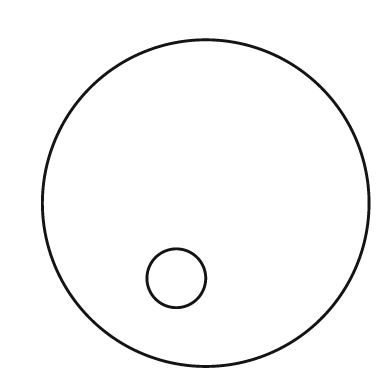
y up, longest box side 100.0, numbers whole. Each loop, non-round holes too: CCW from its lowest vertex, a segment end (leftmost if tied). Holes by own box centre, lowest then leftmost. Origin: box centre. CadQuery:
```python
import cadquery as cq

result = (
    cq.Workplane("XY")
    .moveTo(0.0, 0.0)
    .circle(50.0)
    .moveTo(-9.0, -23.0)
    .circle(9.0)
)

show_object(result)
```